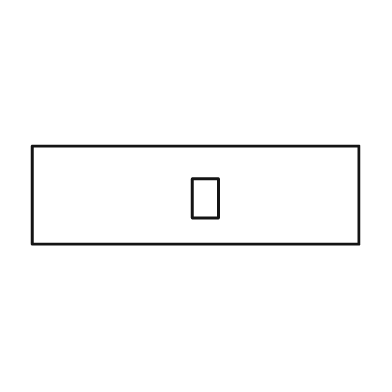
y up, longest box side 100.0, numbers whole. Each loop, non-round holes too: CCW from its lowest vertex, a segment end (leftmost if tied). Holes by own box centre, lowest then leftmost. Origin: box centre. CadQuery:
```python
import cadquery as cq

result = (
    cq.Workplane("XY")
    .moveTo(-50.0, -15.0)
    .lineTo(50.0, -15.0)
    .lineTo(50.0, 15.0)
    .lineTo(-50.0, 15.0)
    .close()
    .moveTo(-1.0, -7.0)
    .lineTo(7.0, -7.0)
    .lineTo(7.0, 5.0)
    .lineTo(-1.0, 5.0)
    .close()
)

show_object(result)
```